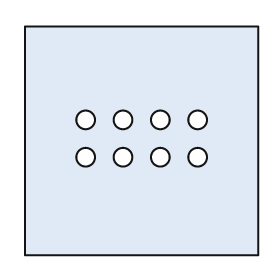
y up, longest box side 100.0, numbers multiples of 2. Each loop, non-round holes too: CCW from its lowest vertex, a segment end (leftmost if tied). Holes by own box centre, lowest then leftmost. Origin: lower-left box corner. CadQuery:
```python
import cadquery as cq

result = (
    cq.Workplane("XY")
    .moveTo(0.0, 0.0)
    .lineTo(100.0, 0.0)
    .lineTo(100.0, 98.0)
    .lineTo(0.0, 98.0)
    .close()
    .moveTo(26.0, 42.0)
    .circle(4.0)
    .moveTo(42.0, 42.0)
    .circle(4.0)
    .moveTo(58.0, 42.0)
    .circle(4.0)
    .moveTo(74.0, 42.0)
    .circle(4.0)
    .moveTo(26.0, 58.0)
    .circle(4.0)
    .moveTo(42.0, 58.0)
    .circle(4.0)
    .moveTo(58.0, 58.0)
    .circle(4.0)
    .moveTo(74.0, 58.0)
    .circle(4.0)
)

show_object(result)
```